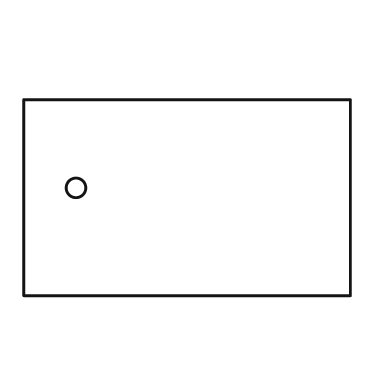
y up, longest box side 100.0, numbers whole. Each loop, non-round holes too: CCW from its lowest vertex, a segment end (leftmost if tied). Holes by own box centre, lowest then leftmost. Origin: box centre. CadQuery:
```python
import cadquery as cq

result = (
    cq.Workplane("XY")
    .moveTo(-50.0, -30.0)
    .lineTo(50.0, -30.0)
    .lineTo(50.0, 30.0)
    .lineTo(-50.0, 30.0)
    .close()
    .moveTo(-34.0, 3.0)
    .circle(3.0)
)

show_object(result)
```